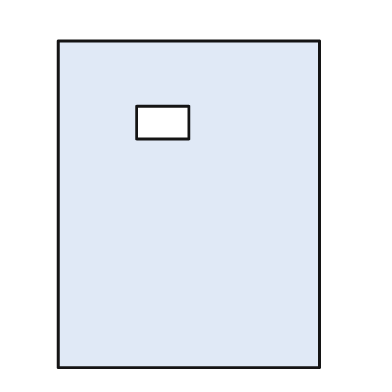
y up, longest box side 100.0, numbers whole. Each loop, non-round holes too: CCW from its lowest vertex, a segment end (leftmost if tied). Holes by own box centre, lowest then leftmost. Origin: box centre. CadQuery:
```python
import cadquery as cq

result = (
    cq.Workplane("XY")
    .moveTo(-40.0, -50.0)
    .lineTo(40.0, -50.0)
    .lineTo(40.0, 50.0)
    .lineTo(-40.0, 50.0)
    .close()
    .moveTo(-16.0, 20.0)
    .lineTo(0.0, 20.0)
    .lineTo(0.0, 30.0)
    .lineTo(-16.0, 30.0)
    .close()
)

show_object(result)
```